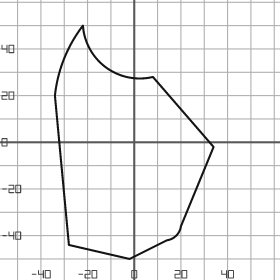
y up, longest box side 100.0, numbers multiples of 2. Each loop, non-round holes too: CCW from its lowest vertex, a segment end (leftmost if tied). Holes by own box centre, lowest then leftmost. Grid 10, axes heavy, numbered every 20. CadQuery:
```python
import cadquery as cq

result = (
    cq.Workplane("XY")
    .moveTo(-2.0, -50.0)
    .lineTo(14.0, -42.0)
    .threePointArc((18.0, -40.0), (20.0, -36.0))
    .lineTo(34.0, -2.0)
    .lineTo(8.0, 28.0)
    .threePointArc((-12.0, 32.0), (-22.0, 50.0))
    .threePointArc((-30.0, 36.0), (-34.0, 20.0))
    .lineTo(-28.0, -44.0)
    .close()
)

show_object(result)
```